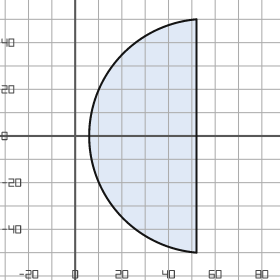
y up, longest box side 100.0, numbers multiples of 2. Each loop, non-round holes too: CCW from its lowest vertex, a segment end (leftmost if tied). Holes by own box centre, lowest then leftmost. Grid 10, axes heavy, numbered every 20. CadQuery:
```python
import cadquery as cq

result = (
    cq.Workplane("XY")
    .moveTo(52.0, -50.0)
    .lineTo(52.0, 50.0)
    .threePointArc((6.0, 0.0), (52.0, -50.0))
    .close()
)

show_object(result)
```